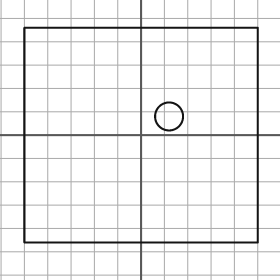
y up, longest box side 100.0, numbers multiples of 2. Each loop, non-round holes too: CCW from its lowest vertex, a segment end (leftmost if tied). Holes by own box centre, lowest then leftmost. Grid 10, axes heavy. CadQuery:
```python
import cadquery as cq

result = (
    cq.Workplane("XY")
    .moveTo(-50.0, -46.0)
    .lineTo(50.0, -46.0)
    .lineTo(50.0, 46.0)
    .lineTo(-50.0, 46.0)
    .close()
    .moveTo(12.0, 8.0)
    .circle(6.0)
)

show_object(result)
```